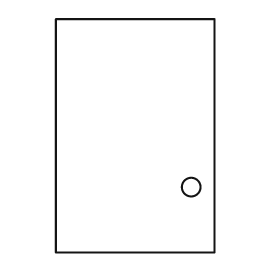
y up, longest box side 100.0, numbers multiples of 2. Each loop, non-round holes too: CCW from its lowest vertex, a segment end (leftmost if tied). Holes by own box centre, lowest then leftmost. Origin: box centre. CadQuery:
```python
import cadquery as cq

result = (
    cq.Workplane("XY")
    .moveTo(-34.0, -50.0)
    .lineTo(34.0, -50.0)
    .lineTo(34.0, 50.0)
    .lineTo(-34.0, 50.0)
    .close()
    .moveTo(24.0, -22.0)
    .circle(4.0)
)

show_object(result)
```